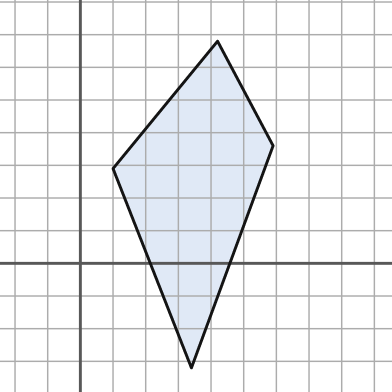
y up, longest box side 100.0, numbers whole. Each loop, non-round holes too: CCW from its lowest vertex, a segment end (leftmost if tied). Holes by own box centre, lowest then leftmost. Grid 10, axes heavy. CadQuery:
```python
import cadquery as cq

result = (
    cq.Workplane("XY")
    .moveTo(34.0, -32.0)
    .lineTo(59.0, 36.0)
    .lineTo(42.0, 68.0)
    .lineTo(10.0, 29.0)
    .close()
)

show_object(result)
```